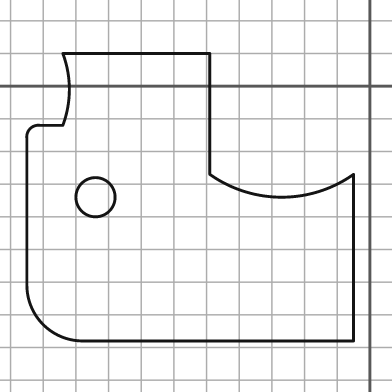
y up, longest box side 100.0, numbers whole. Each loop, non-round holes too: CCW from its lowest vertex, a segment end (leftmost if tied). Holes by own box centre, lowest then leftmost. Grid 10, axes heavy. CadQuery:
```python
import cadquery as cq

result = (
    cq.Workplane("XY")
    .moveTo(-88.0, -78.0)
    .lineTo(-5.0, -78.0)
    .lineTo(-5.0, -27.0)
    .threePointArc((-27.0, -34.0), (-49.0, -27.0))
    .lineTo(-49.0, 10.0)
    .lineTo(-94.0, 10.0)
    .threePointArc((-92.0, -1.0), (-94.0, -12.0))
    .lineTo(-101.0, -12.0)
    .threePointArc((-104.0, -13.0), (-105.0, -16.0))
    .lineTo(-105.0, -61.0)
    .threePointArc((-100.0, -73.0), (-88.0, -78.0))
    .close()
    .moveTo(-84.0, -34.0)
    .circle(6.0)
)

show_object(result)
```